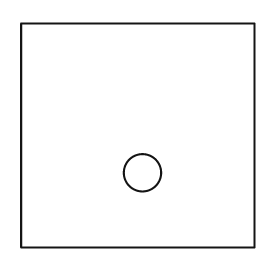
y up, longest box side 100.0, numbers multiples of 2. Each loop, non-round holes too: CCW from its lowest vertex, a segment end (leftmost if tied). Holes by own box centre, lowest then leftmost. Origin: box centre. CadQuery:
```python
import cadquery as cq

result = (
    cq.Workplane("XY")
    .moveTo(-50.0, -48.0)
    .lineTo(50.0, -48.0)
    .lineTo(50.0, 48.0)
    .lineTo(-50.0, 48.0)
    .close()
    .moveTo(2.0, -16.0)
    .circle(8.0)
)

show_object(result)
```